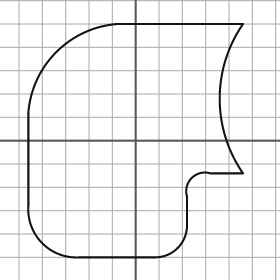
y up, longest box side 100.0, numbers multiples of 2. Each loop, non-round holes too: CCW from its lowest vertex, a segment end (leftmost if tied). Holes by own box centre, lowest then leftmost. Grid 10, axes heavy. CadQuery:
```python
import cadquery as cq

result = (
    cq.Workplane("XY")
    .moveTo(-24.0, -50.0)
    .lineTo(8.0, -50.0)
    .threePointArc((18.0, -46.0), (22.0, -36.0))
    .lineTo(22.0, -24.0)
    .threePointArc((24.0, -16.0), (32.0, -14.0))
    .lineTo(46.0, -14.0)
    .threePointArc((36.0, 18.0), (46.0, 50.0))
    .lineTo(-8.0, 50.0)
    .threePointArc((-34.0, 38.0), (-46.0, 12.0))
    .lineTo(-46.0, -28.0)
    .threePointArc((-40.0, -44.0), (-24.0, -50.0))
    .close()
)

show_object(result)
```